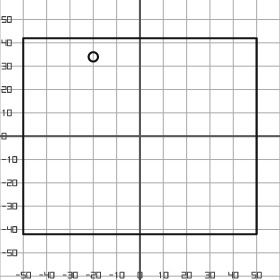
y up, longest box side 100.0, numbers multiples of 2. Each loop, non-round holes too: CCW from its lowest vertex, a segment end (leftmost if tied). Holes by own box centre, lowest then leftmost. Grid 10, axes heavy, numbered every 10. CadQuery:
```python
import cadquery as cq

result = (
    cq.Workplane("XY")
    .moveTo(-50.0, -42.0)
    .lineTo(50.0, -42.0)
    .lineTo(50.0, 42.0)
    .lineTo(-50.0, 42.0)
    .close()
    .moveTo(-20.0, 34.0)
    .circle(2.0)
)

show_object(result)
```